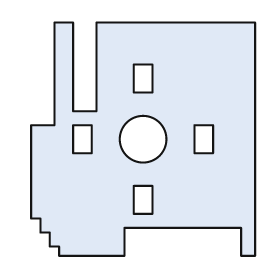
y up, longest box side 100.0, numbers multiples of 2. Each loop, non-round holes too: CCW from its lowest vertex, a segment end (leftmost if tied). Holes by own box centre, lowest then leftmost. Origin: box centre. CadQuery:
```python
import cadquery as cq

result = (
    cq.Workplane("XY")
    .moveTo(-36.0, -50.0)
    .lineTo(-8.0, -50.0)
    .lineTo(-8.0, -38.0)
    .lineTo(42.0, -38.0)
    .lineTo(42.0, -50.0)
    .lineTo(48.0, -50.0)
    .lineTo(48.0, 50.0)
    .lineTo(-20.0, 50.0)
    .lineTo(-20.0, 12.0)
    .lineTo(-30.0, 12.0)
    .lineTo(-30.0, 50.0)
    .lineTo(-38.0, 50.0)
    .lineTo(-38.0, 6.0)
    .lineTo(-48.0, 6.0)
    .lineTo(-48.0, -34.0)
    .lineTo(-44.0, -34.0)
    .lineTo(-44.0, -40.0)
    .lineTo(-40.0, -40.0)
    .lineTo(-40.0, -46.0)
    .lineTo(-36.0, -46.0)
    .close()
    .moveTo(-4.0, -32.0)
    .lineTo(4.0, -32.0)
    .lineTo(4.0, -20.0)
    .lineTo(-4.0, -20.0)
    .close()
    .moveTo(-30.0, -6.0)
    .lineTo(-22.0, -6.0)
    .lineTo(-22.0, 6.0)
    .lineTo(-30.0, 6.0)
    .close()
    .moveTo(0.0, 0.0)
    .circle(10.0)
    .moveTo(22.0, -6.0)
    .lineTo(30.0, -6.0)
    .lineTo(30.0, 6.0)
    .lineTo(22.0, 6.0)
    .close()
    .moveTo(-4.0, 20.0)
    .lineTo(4.0, 20.0)
    .lineTo(4.0, 32.0)
    .lineTo(-4.0, 32.0)
    .close()
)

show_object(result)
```